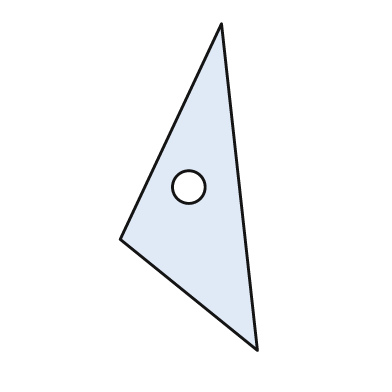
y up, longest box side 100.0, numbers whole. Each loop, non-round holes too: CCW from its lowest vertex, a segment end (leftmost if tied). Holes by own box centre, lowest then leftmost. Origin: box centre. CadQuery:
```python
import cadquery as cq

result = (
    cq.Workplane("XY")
    .moveTo(21.0, -50.0)
    .lineTo(10.0, 50.0)
    .lineTo(-21.0, -16.0)
    .close()
    .moveTo(0.0, 0.0)
    .circle(5.0)
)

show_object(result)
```